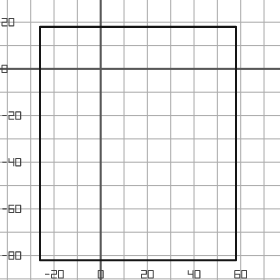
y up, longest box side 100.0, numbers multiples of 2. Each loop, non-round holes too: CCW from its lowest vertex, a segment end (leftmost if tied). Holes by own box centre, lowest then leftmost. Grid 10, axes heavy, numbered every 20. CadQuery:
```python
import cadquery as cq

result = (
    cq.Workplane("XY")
    .moveTo(-26.0, -82.0)
    .lineTo(58.0, -82.0)
    .lineTo(58.0, 18.0)
    .lineTo(-26.0, 18.0)
    .close()
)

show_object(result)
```